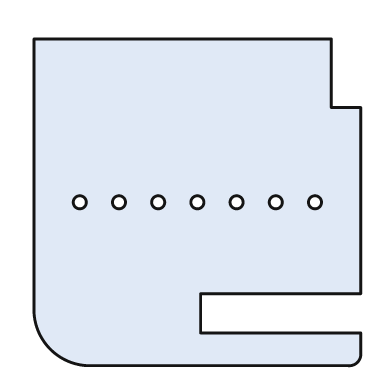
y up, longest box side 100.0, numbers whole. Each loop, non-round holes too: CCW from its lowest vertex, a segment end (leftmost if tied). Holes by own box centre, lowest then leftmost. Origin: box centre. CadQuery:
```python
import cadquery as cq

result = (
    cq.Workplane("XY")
    .moveTo(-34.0, -50.0)
    .lineTo(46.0, -50.0)
    .threePointArc((49.0, -49.0), (50.0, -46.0))
    .lineTo(50.0, -40.0)
    .lineTo(1.0, -40.0)
    .lineTo(1.0, -28.0)
    .lineTo(50.0, -28.0)
    .lineTo(50.0, 29.0)
    .lineTo(41.0, 29.0)
    .lineTo(41.0, 50.0)
    .lineTo(-50.0, 50.0)
    .lineTo(-50.0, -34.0)
    .threePointArc((-45.0, -45.0), (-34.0, -50.0))
    .close()
    .moveTo(-36.0, 0.0)
    .circle(2.0)
    .moveTo(-24.0, 0.0)
    .circle(2.0)
    .moveTo(-12.0, 0.0)
    .circle(2.0)
    .moveTo(0.0, 0.0)
    .circle(2.0)
    .moveTo(12.0, 0.0)
    .circle(2.0)
    .moveTo(24.0, 0.0)
    .circle(2.0)
    .moveTo(36.0, 0.0)
    .circle(2.0)
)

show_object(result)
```